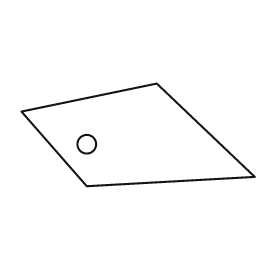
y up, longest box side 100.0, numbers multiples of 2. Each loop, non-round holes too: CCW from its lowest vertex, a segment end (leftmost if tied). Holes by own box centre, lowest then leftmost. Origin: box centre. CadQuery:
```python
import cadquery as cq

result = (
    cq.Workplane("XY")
    .moveTo(-22.0, -22.0)
    .lineTo(50.0, -18.0)
    .lineTo(8.0, 22.0)
    .lineTo(-50.0, 10.0)
    .close()
    .moveTo(-22.0, -4.0)
    .circle(4.0)
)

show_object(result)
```